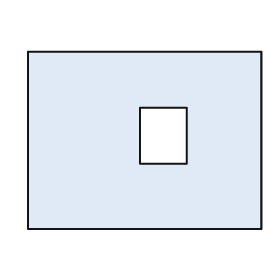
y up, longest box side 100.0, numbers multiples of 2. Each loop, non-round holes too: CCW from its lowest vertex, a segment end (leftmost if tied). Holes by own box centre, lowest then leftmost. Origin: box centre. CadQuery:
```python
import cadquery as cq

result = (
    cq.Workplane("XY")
    .moveTo(-50.0, -38.0)
    .lineTo(50.0, -38.0)
    .lineTo(50.0, 38.0)
    .lineTo(-50.0, 38.0)
    .close()
    .moveTo(-2.0, -10.0)
    .lineTo(18.0, -10.0)
    .lineTo(18.0, 14.0)
    .lineTo(-2.0, 14.0)
    .close()
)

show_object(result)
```